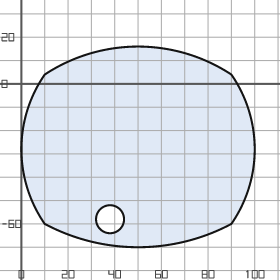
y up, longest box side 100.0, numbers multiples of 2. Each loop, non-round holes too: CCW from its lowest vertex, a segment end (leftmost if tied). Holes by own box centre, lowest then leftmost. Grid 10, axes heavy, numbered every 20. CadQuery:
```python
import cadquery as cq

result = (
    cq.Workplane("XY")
    .moveTo(10.0, -60.0)
    .threePointArc((50.0, -70.0), (90.0, -60.0))
    .threePointArc((100.0, -28.0), (90.0, 4.0))
    .threePointArc((50.0, 16.0), (10.0, 4.0))
    .threePointArc((0.0, -28.0), (10.0, -60.0))
    .close()
    .moveTo(38.0, -58.0)
    .circle(6.0)
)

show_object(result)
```